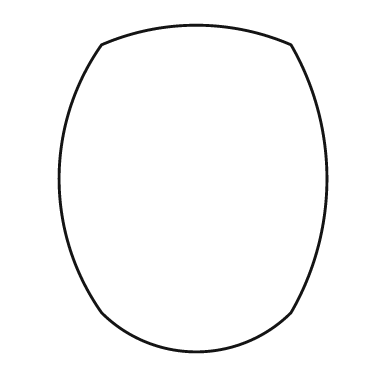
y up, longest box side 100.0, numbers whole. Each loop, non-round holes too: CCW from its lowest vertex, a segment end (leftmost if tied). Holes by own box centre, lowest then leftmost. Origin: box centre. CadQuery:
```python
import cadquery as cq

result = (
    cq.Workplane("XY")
    .moveTo(-28.0, -38.0)
    .threePointArc((1.0, -50.0), (30.0, -38.0))
    .threePointArc((41.0, 3.0), (30.0, 44.0))
    .threePointArc((1.0, 50.0), (-28.0, 44.0))
    .threePointArc((-41.0, 3.0), (-28.0, -38.0))
    .close()
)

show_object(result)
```